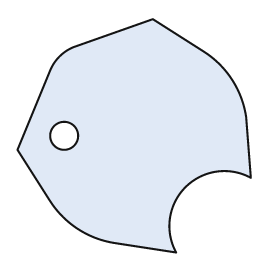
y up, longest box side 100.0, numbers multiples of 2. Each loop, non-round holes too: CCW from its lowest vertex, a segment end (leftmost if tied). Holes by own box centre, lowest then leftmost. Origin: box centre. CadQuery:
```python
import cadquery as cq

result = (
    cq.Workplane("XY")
    .moveTo(18.0, -50.0)
    .threePointArc((22.0, -22.0), (50.0, -18.0))
    .lineTo(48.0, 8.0)
    .threePointArc((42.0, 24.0), (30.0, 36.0))
    .lineTo(8.0, 50.0)
    .lineTo(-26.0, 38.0)
    .threePointArc((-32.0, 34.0), (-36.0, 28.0))
    .lineTo(-50.0, -6.0)
    .lineTo(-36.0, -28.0)
    .threePointArc((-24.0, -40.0), (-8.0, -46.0))
    .close()
    .moveTo(-30.0, 0.0)
    .circle(6.0)
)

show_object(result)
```